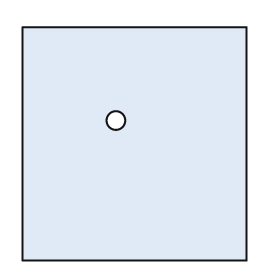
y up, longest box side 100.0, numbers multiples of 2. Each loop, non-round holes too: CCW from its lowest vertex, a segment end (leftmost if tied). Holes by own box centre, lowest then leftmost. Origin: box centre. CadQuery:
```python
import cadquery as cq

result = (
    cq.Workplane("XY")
    .moveTo(-48.0, -50.0)
    .lineTo(48.0, -50.0)
    .lineTo(48.0, 50.0)
    .lineTo(-48.0, 50.0)
    .close()
    .moveTo(-8.0, 10.0)
    .circle(4.0)
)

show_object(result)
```